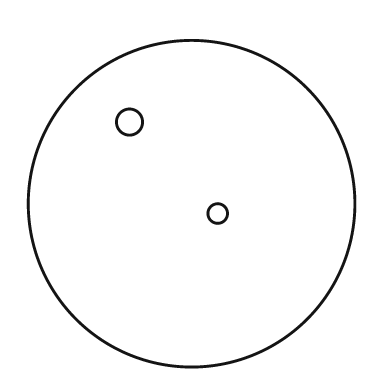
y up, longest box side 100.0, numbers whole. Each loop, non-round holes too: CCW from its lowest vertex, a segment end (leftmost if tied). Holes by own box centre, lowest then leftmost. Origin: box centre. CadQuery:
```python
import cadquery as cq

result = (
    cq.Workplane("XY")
    .moveTo(0.0, 0.0)
    .circle(50.0)
    .moveTo(8.0, -3.0)
    .circle(3.0)
    .moveTo(-19.0, 25.0)
    .circle(4.0)
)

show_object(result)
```